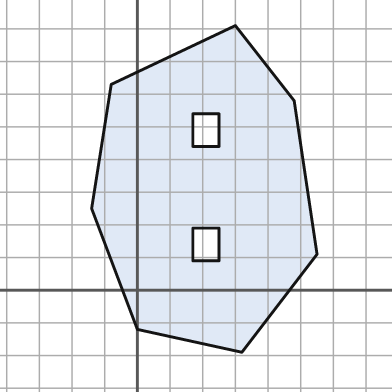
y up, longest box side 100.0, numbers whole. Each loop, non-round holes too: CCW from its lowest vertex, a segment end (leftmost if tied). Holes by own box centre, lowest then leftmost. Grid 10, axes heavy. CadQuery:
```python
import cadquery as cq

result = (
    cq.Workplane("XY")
    .moveTo(32.0, -19.0)
    .lineTo(55.0, 11.0)
    .lineTo(48.0, 58.0)
    .lineTo(30.0, 81.0)
    .lineTo(-8.0, 63.0)
    .lineTo(-14.0, 25.0)
    .lineTo(0.0, -12.0)
    .close()
    .moveTo(17.0, 9.0)
    .lineTo(25.0, 9.0)
    .lineTo(25.0, 19.0)
    .lineTo(17.0, 19.0)
    .close()
    .moveTo(17.0, 44.0)
    .lineTo(25.0, 44.0)
    .lineTo(25.0, 54.0)
    .lineTo(17.0, 54.0)
    .close()
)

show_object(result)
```